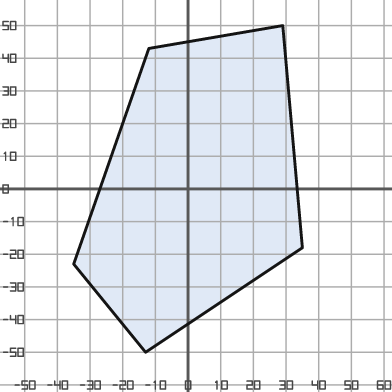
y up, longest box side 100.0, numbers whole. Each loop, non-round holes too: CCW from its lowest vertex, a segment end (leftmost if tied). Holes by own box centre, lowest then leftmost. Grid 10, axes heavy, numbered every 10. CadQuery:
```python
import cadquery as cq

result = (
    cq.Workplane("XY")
    .moveTo(-13.0, -50.0)
    .lineTo(35.0, -18.0)
    .lineTo(29.0, 50.0)
    .lineTo(-12.0, 43.0)
    .lineTo(-35.0, -23.0)
    .close()
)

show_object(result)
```